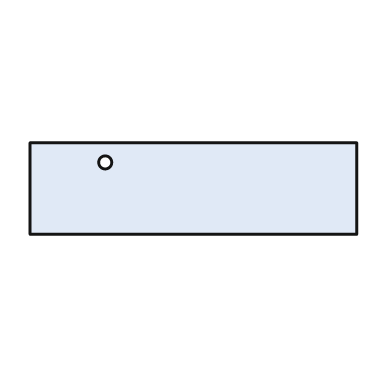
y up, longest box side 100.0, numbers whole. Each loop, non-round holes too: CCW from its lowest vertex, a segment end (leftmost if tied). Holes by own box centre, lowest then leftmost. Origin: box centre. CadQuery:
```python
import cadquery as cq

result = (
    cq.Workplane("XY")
    .moveTo(-50.0, -14.0)
    .lineTo(50.0, -14.0)
    .lineTo(50.0, 14.0)
    .lineTo(-50.0, 14.0)
    .close()
    .moveTo(-27.0, 8.0)
    .circle(2.0)
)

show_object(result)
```